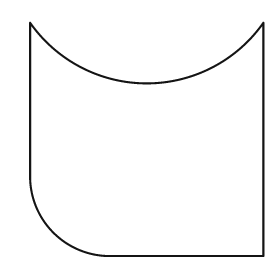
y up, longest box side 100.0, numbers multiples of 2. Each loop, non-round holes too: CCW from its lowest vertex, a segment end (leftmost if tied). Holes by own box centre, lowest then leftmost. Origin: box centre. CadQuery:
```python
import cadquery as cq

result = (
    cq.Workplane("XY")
    .moveTo(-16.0, -50.0)
    .lineTo(50.0, -50.0)
    .lineTo(50.0, 50.0)
    .threePointArc((0.0, 24.0), (-50.0, 50.0))
    .lineTo(-50.0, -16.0)
    .threePointArc((-40.0, -40.0), (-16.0, -50.0))
    .close()
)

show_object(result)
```